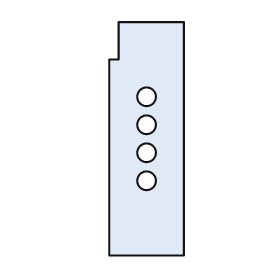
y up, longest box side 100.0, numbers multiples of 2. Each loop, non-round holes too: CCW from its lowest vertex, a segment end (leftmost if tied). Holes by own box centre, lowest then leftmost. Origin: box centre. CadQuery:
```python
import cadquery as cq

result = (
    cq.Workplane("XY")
    .moveTo(-16.0, -50.0)
    .lineTo(16.0, -50.0)
    .lineTo(16.0, 50.0)
    .lineTo(-12.0, 50.0)
    .lineTo(-12.0, 34.0)
    .lineTo(-16.0, 34.0)
    .close()
    .moveTo(0.0, -18.0)
    .circle(4.0)
    .moveTo(0.0, -6.0)
    .circle(4.0)
    .moveTo(0.0, 6.0)
    .circle(4.0)
    .moveTo(0.0, 18.0)
    .circle(4.0)
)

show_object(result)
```